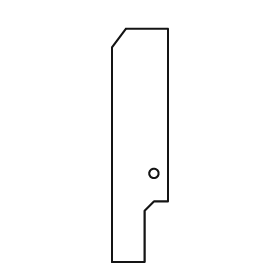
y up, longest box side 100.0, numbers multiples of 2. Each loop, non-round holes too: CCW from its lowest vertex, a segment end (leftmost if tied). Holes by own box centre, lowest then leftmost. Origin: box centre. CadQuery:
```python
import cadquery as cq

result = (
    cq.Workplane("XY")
    .moveTo(-12.0, -50.0)
    .lineTo(2.0, -50.0)
    .lineTo(2.0, -28.0)
    .lineTo(6.0, -24.0)
    .lineTo(12.0, -24.0)
    .lineTo(12.0, 50.0)
    .lineTo(-6.0, 50.0)
    .lineTo(-12.0, 42.0)
    .close()
    .moveTo(6.0, -12.0)
    .circle(2.0)
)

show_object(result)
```